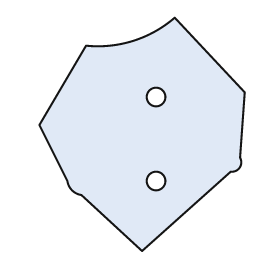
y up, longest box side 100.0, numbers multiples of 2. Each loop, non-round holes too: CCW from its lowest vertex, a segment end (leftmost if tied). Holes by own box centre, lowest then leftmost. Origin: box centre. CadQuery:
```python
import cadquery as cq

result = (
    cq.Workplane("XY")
    .moveTo(0.0, -50.0)
    .lineTo(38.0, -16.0)
    .threePointArc((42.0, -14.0), (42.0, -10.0))
    .lineTo(44.0, 18.0)
    .lineTo(14.0, 50.0)
    .threePointArc((-4.0, 40.0), (-24.0, 38.0))
    .lineTo(-44.0, 4.0)
    .lineTo(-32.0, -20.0)
    .threePointArc((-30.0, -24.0), (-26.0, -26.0))
    .close()
    .moveTo(6.0, -20.0)
    .circle(4.0)
    .moveTo(6.0, 16.0)
    .circle(4.0)
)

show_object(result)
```